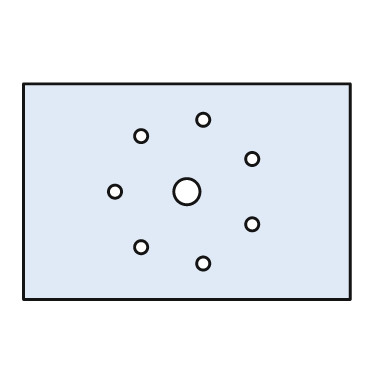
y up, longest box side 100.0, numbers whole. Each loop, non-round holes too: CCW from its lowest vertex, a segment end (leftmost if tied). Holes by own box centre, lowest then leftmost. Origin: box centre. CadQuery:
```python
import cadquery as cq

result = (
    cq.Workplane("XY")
    .moveTo(-50.0, -33.0)
    .lineTo(50.0, -33.0)
    .lineTo(50.0, 33.0)
    .lineTo(-50.0, 33.0)
    .close()
    .moveTo(5.0, -22.0)
    .circle(2.0)
    .moveTo(-14.0, -17.0)
    .circle(2.0)
    .moveTo(20.0, -10.0)
    .circle(2.0)
    .moveTo(-22.0, 0.0)
    .circle(2.0)
    .moveTo(0.0, 0.0)
    .circle(4.0)
    .moveTo(20.0, 10.0)
    .circle(2.0)
    .moveTo(-14.0, 17.0)
    .circle(2.0)
    .moveTo(5.0, 22.0)
    .circle(2.0)
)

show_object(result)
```